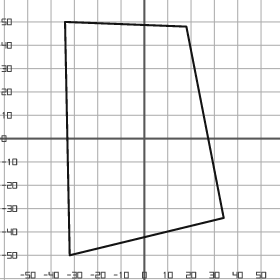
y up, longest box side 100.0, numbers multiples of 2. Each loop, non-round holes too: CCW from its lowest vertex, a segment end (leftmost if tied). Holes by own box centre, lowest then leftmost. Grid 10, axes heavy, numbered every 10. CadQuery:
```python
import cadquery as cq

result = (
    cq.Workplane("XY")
    .moveTo(-32.0, -50.0)
    .lineTo(34.0, -34.0)
    .lineTo(18.0, 48.0)
    .lineTo(-34.0, 50.0)
    .close()
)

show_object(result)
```